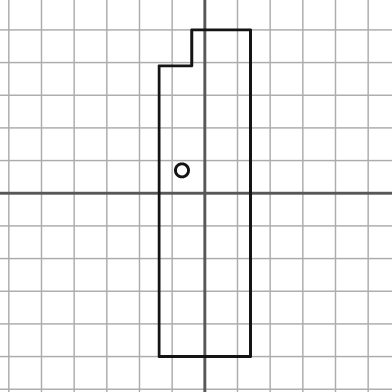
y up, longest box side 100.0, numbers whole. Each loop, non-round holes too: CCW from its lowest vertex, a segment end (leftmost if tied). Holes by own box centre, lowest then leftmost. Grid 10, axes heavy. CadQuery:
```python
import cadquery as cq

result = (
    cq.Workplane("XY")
    .moveTo(-14.0, -50.0)
    .lineTo(14.0, -50.0)
    .lineTo(14.0, 50.0)
    .lineTo(-4.0, 50.0)
    .lineTo(-4.0, 39.0)
    .lineTo(-14.0, 39.0)
    .close()
    .moveTo(-7.0, 7.0)
    .circle(2.0)
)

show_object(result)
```